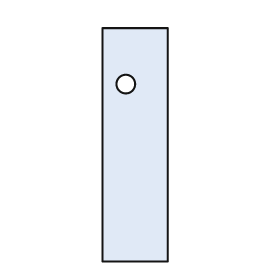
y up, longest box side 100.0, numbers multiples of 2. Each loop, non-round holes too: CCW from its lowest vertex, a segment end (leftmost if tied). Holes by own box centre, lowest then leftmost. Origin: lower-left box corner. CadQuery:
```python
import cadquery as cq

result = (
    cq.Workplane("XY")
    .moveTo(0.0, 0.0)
    .lineTo(28.0, 0.0)
    .lineTo(28.0, 100.0)
    .lineTo(0.0, 100.0)
    .close()
    .moveTo(10.0, 76.0)
    .circle(4.0)
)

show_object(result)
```